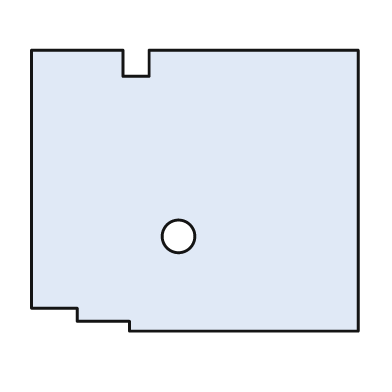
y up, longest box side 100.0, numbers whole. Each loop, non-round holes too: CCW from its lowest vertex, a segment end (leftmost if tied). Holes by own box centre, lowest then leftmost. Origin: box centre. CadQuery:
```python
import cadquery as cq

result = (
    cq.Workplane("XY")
    .moveTo(-20.0, -43.0)
    .lineTo(50.0, -43.0)
    .lineTo(50.0, 43.0)
    .lineTo(-14.0, 43.0)
    .lineTo(-14.0, 35.0)
    .lineTo(-22.0, 35.0)
    .lineTo(-22.0, 43.0)
    .lineTo(-50.0, 43.0)
    .lineTo(-50.0, -36.0)
    .lineTo(-36.0, -36.0)
    .lineTo(-36.0, -40.0)
    .lineTo(-20.0, -40.0)
    .close()
    .moveTo(-5.0, -14.0)
    .circle(5.0)
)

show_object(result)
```